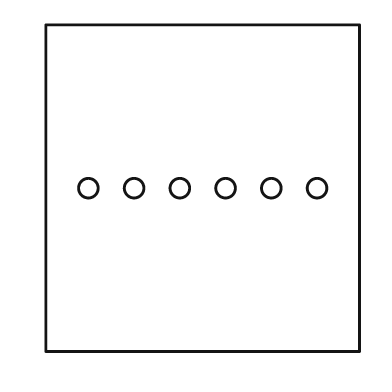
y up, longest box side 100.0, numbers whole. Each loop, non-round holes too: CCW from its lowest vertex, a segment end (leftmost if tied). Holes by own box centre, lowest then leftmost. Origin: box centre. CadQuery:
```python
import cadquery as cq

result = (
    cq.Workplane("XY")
    .moveTo(-48.0, -50.0)
    .lineTo(48.0, -50.0)
    .lineTo(48.0, 50.0)
    .lineTo(-48.0, 50.0)
    .close()
    .moveTo(-35.0, 0.0)
    .circle(3.0)
    .moveTo(-21.0, 0.0)
    .circle(3.0)
    .moveTo(-7.0, 0.0)
    .circle(3.0)
    .moveTo(7.0, 0.0)
    .circle(3.0)
    .moveTo(21.0, 0.0)
    .circle(3.0)
    .moveTo(35.0, 0.0)
    .circle(3.0)
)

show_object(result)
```